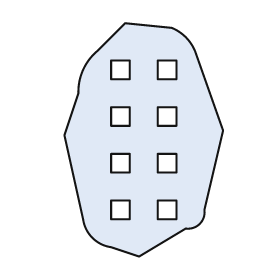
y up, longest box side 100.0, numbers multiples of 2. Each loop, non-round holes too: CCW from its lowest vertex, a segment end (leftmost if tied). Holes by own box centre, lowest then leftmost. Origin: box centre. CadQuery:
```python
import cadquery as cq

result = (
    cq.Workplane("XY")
    .moveTo(-2.0, -50.0)
    .lineTo(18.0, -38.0)
    .threePointArc((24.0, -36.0), (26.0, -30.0))
    .lineTo(34.0, 4.0)
    .lineTo(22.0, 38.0)
    .threePointArc((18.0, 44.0), (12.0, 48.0))
    .lineTo(-8.0, 50.0)
    .lineTo(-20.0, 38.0)
    .threePointArc((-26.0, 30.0), (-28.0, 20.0))
    .lineTo(-34.0, 2.0)
    .lineTo(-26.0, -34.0)
    .threePointArc((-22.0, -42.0), (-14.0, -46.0))
    .close()
    .moveTo(-14.0, -34.0)
    .lineTo(-6.0, -34.0)
    .lineTo(-6.0, -26.0)
    .lineTo(-14.0, -26.0)
    .close()
    .moveTo(6.0, -34.0)
    .lineTo(14.0, -34.0)
    .lineTo(14.0, -26.0)
    .lineTo(6.0, -26.0)
    .close()
    .moveTo(-14.0, -14.0)
    .lineTo(-6.0, -14.0)
    .lineTo(-6.0, -6.0)
    .lineTo(-14.0, -6.0)
    .close()
    .moveTo(6.0, -14.0)
    .lineTo(14.0, -14.0)
    .lineTo(14.0, -6.0)
    .lineTo(6.0, -6.0)
    .close()
    .moveTo(-14.0, 6.0)
    .lineTo(-6.0, 6.0)
    .lineTo(-6.0, 14.0)
    .lineTo(-14.0, 14.0)
    .close()
    .moveTo(6.0, 6.0)
    .lineTo(14.0, 6.0)
    .lineTo(14.0, 14.0)
    .lineTo(6.0, 14.0)
    .close()
    .moveTo(-14.0, 26.0)
    .lineTo(-6.0, 26.0)
    .lineTo(-6.0, 34.0)
    .lineTo(-14.0, 34.0)
    .close()
    .moveTo(6.0, 26.0)
    .lineTo(14.0, 26.0)
    .lineTo(14.0, 34.0)
    .lineTo(6.0, 34.0)
    .close()
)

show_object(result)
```